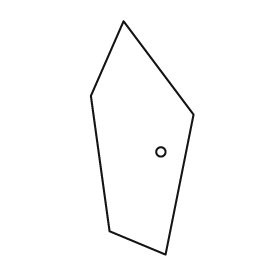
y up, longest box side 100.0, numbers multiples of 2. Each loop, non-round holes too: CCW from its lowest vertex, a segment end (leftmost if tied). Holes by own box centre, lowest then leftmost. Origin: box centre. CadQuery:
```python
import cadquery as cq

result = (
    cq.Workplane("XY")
    .moveTo(10.0, -50.0)
    .lineTo(22.0, 10.0)
    .lineTo(-8.0, 50.0)
    .lineTo(-22.0, 18.0)
    .lineTo(-14.0, -40.0)
    .close()
    .moveTo(8.0, -6.0)
    .circle(2.0)
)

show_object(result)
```